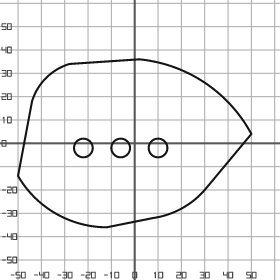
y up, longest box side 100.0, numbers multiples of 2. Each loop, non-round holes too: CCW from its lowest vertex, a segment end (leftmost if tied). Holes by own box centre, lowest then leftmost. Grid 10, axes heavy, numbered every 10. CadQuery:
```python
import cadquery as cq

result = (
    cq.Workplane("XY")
    .moveTo(-12.0, -36.0)
    .lineTo(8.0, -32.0)
    .threePointArc((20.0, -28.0), (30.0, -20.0))
    .lineTo(50.0, 4.0)
    .threePointArc((30.0, 26.0), (2.0, 36.0))
    .lineTo(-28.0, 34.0)
    .threePointArc((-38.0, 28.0), (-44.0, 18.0))
    .lineTo(-50.0, -14.0)
    .threePointArc((-34.0, -30.0), (-12.0, -36.0))
    .close()
    .moveTo(-22.0, -2.0)
    .circle(4.0)
    .moveTo(-6.0, -2.0)
    .circle(4.0)
    .moveTo(10.0, -2.0)
    .circle(4.0)
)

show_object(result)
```